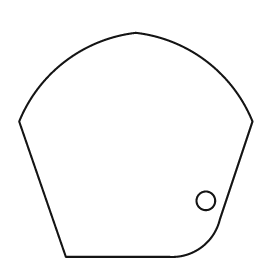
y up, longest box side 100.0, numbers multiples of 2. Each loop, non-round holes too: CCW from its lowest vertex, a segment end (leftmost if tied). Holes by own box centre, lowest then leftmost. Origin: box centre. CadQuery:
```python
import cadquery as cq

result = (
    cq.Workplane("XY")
    .moveTo(-30.0, -48.0)
    .lineTo(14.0, -48.0)
    .threePointArc((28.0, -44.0), (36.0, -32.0))
    .lineTo(50.0, 10.0)
    .threePointArc((30.0, 36.0), (0.0, 48.0))
    .threePointArc((-30.0, 36.0), (-50.0, 10.0))
    .close()
    .moveTo(30.0, -24.0)
    .circle(4.0)
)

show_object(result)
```